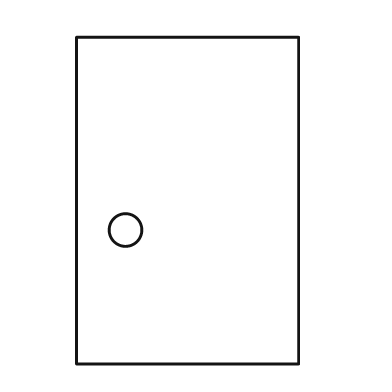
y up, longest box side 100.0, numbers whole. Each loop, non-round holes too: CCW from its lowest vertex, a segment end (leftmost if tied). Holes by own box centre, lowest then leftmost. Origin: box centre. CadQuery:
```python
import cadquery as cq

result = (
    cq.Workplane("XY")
    .moveTo(-34.0, -50.0)
    .lineTo(34.0, -50.0)
    .lineTo(34.0, 50.0)
    .lineTo(-34.0, 50.0)
    .close()
    .moveTo(-19.0, -9.0)
    .circle(5.0)
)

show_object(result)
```